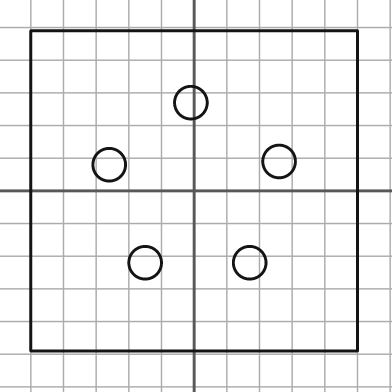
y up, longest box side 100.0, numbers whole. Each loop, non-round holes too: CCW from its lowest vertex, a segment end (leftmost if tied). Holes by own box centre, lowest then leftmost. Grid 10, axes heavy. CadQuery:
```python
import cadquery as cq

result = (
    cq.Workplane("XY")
    .moveTo(-50.0, -49.0)
    .lineTo(50.0, -49.0)
    .lineTo(50.0, 49.0)
    .lineTo(-50.0, 49.0)
    .close()
    .moveTo(-15.0, -22.0)
    .circle(5.0)
    .moveTo(17.0, -22.0)
    .circle(5.0)
    .moveTo(-26.0, 8.0)
    .circle(5.0)
    .moveTo(26.0, 9.0)
    .circle(5.0)
    .moveTo(-1.0, 27.0)
    .circle(5.0)
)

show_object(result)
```